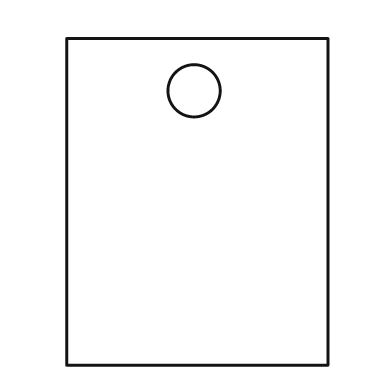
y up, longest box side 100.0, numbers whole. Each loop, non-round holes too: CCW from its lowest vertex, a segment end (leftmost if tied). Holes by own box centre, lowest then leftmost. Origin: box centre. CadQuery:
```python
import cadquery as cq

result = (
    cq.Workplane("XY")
    .moveTo(-40.0, -50.0)
    .lineTo(40.0, -50.0)
    .lineTo(40.0, 50.0)
    .lineTo(-40.0, 50.0)
    .close()
    .moveTo(-1.0, 34.0)
    .circle(8.0)
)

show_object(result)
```